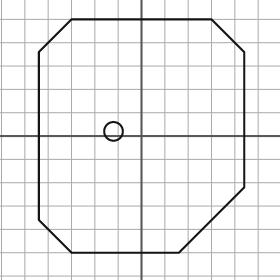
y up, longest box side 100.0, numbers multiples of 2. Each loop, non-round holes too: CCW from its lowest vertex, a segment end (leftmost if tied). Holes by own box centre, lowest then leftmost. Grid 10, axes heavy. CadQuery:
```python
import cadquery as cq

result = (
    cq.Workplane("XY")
    .moveTo(-30.0, -50.0)
    .lineTo(16.0, -50.0)
    .lineTo(44.0, -22.0)
    .lineTo(44.0, 36.0)
    .lineTo(30.0, 50.0)
    .lineTo(-30.0, 50.0)
    .lineTo(-44.0, 36.0)
    .lineTo(-44.0, -36.0)
    .close()
    .moveTo(-12.0, 2.0)
    .circle(4.0)
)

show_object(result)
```